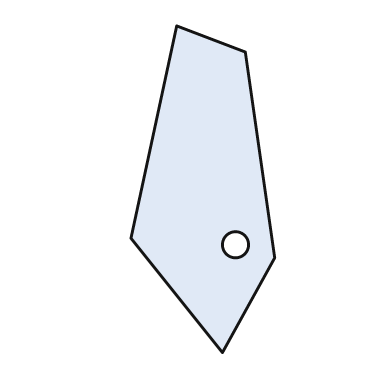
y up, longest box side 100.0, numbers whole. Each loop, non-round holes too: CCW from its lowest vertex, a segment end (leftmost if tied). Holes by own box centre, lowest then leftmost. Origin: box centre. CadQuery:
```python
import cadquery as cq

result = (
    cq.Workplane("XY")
    .moveTo(6.0, -50.0)
    .lineTo(22.0, -21.0)
    .lineTo(13.0, 42.0)
    .lineTo(-8.0, 50.0)
    .lineTo(-22.0, -15.0)
    .close()
    .moveTo(10.0, -17.0)
    .circle(4.0)
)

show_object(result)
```